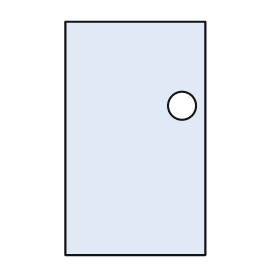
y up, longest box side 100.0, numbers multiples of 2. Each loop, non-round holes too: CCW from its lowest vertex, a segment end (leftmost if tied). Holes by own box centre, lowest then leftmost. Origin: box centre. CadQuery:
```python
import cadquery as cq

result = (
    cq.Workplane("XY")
    .moveTo(-30.0, -50.0)
    .lineTo(30.0, -50.0)
    .lineTo(30.0, 50.0)
    .lineTo(-30.0, 50.0)
    .close()
    .moveTo(20.0, 14.0)
    .circle(6.0)
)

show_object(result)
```